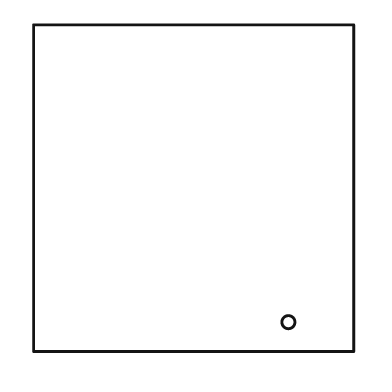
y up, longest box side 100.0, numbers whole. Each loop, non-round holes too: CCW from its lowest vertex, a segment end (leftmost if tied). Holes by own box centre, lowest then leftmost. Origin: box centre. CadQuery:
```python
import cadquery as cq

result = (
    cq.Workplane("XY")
    .moveTo(-49.0, -50.0)
    .lineTo(49.0, -50.0)
    .lineTo(49.0, 50.0)
    .lineTo(-49.0, 50.0)
    .close()
    .moveTo(29.0, -41.0)
    .circle(2.0)
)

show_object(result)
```